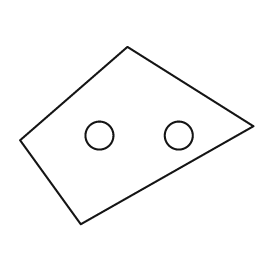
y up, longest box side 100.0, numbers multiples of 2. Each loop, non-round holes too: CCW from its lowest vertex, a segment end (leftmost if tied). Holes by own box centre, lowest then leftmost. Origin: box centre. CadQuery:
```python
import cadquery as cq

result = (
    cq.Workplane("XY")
    .moveTo(-24.0, -38.0)
    .lineTo(50.0, 4.0)
    .lineTo(-4.0, 38.0)
    .lineTo(-50.0, -2.0)
    .close()
    .moveTo(-16.0, 0.0)
    .circle(6.0)
    .moveTo(18.0, 0.0)
    .circle(6.0)
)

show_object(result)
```